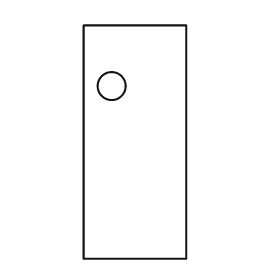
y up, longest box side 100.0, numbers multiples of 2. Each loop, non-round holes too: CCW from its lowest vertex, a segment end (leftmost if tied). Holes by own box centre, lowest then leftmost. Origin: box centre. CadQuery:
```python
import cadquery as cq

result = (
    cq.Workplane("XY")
    .moveTo(-22.0, -50.0)
    .lineTo(22.0, -50.0)
    .lineTo(22.0, 50.0)
    .lineTo(-22.0, 50.0)
    .close()
    .moveTo(-10.0, 24.0)
    .circle(6.0)
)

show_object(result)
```